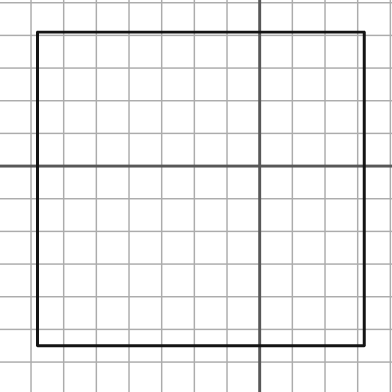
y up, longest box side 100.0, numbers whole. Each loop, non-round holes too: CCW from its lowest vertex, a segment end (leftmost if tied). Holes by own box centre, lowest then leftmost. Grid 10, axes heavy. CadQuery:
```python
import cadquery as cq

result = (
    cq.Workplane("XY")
    .moveTo(-68.0, -55.0)
    .lineTo(32.0, -55.0)
    .lineTo(32.0, 41.0)
    .lineTo(-68.0, 41.0)
    .close()
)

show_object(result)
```